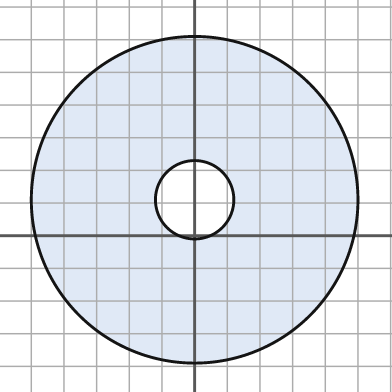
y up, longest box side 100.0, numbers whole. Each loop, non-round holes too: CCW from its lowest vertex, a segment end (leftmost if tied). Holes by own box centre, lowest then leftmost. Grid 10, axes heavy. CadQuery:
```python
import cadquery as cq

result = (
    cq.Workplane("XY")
    .moveTo(0.0, 11.0)
    .circle(50.0)
    .moveTo(0.0, 11.0)
    .circle(12.0)
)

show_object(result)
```